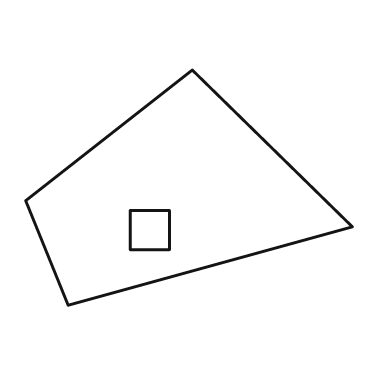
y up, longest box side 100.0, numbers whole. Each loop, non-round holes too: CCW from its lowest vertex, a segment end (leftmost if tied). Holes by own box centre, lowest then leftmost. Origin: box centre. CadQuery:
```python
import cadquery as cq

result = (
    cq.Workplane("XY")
    .moveTo(-37.0, -36.0)
    .lineTo(50.0, -12.0)
    .lineTo(1.0, 36.0)
    .lineTo(-50.0, -4.0)
    .close()
    .moveTo(-18.0, -19.0)
    .lineTo(-6.0, -19.0)
    .lineTo(-6.0, -7.0)
    .lineTo(-18.0, -7.0)
    .close()
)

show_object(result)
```